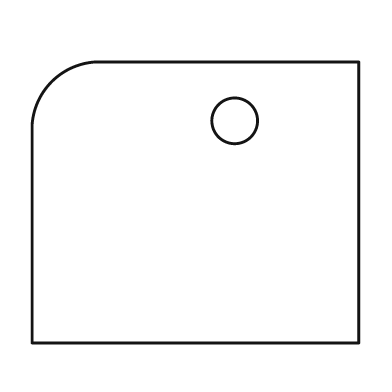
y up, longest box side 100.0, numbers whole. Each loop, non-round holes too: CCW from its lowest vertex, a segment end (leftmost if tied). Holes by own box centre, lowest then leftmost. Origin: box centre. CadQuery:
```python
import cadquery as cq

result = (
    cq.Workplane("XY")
    .moveTo(-50.0, -43.0)
    .lineTo(50.0, -43.0)
    .lineTo(50.0, 43.0)
    .lineTo(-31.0, 43.0)
    .threePointArc((-44.0, 37.0), (-50.0, 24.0))
    .close()
    .moveTo(12.0, 25.0)
    .circle(7.0)
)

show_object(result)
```